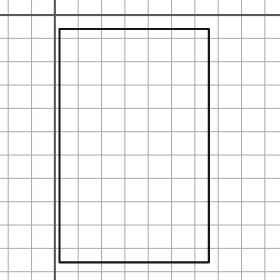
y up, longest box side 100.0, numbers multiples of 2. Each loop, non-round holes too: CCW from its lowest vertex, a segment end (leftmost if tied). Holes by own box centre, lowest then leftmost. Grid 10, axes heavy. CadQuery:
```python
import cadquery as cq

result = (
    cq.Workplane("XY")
    .moveTo(2.0, -106.0)
    .lineTo(66.0, -106.0)
    .lineTo(66.0, -6.0)
    .lineTo(2.0, -6.0)
    .close()
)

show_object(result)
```